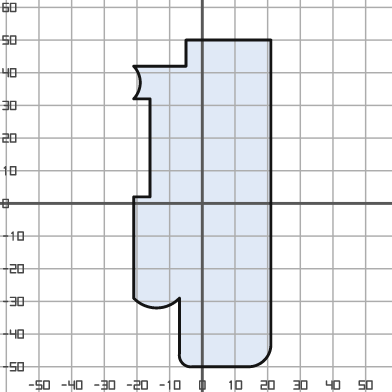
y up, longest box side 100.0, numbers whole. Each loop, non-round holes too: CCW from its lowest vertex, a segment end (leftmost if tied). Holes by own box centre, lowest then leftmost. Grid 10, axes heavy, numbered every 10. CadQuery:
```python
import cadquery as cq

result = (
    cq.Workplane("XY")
    .moveTo(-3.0, -50.0)
    .lineTo(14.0, -50.0)
    .threePointArc((19.0, -48.0), (21.0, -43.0))
    .lineTo(21.0, 50.0)
    .lineTo(-5.0, 50.0)
    .lineTo(-5.0, 42.0)
    .lineTo(-21.0, 42.0)
    .threePointArc((-19.0, 37.0), (-21.0, 32.0))
    .lineTo(-16.0, 32.0)
    .lineTo(-16.0, 2.0)
    .lineTo(-21.0, 2.0)
    .lineTo(-21.0, -29.0)
    .threePointArc((-14.0, -32.0), (-7.0, -29.0))
    .lineTo(-7.0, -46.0)
    .threePointArc((-6.0, -49.0), (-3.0, -50.0))
    .close()
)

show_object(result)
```